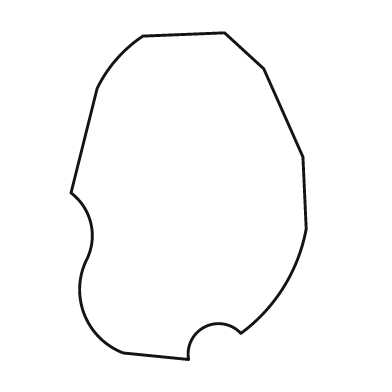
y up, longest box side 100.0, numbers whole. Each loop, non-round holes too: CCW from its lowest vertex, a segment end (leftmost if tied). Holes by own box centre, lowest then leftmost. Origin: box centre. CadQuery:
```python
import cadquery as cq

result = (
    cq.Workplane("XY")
    .moveTo(0.0, -50.0)
    .threePointArc((5.0, -40.0), (16.0, -42.0))
    .threePointArc((29.0, -28.0), (36.0, -10.0))
    .lineTo(35.0, 12.0)
    .lineTo(23.0, 39.0)
    .lineTo(11.0, 50.0)
    .lineTo(-14.0, 49.0)
    .threePointArc((-22.0, 42.0), (-28.0, 33.0))
    .lineTo(-36.0, 1.0)
    .threePointArc((-30.0, -8.0), (-31.0, -19.0))
    .threePointArc((-32.0, -36.0), (-20.0, -48.0))
    .close()
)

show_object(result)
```